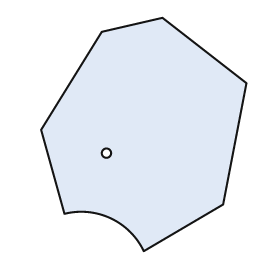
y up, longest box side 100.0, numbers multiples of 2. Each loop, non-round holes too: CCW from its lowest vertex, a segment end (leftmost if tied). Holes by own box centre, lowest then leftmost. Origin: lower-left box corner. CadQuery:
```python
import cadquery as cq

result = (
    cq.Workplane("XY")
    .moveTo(44.0, 0.0)
    .lineTo(78.0, 20.0)
    .lineTo(88.0, 72.0)
    .lineTo(52.0, 100.0)
    .lineTo(26.0, 94.0)
    .lineTo(0.0, 52.0)
    .lineTo(10.0, 16.0)
    .threePointArc((30.0, 14.0), (44.0, 0.0))
    .close()
    .moveTo(28.0, 42.0)
    .circle(2.0)
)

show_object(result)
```